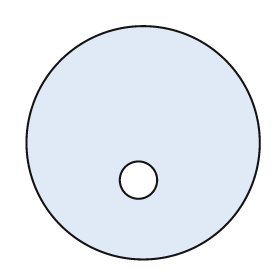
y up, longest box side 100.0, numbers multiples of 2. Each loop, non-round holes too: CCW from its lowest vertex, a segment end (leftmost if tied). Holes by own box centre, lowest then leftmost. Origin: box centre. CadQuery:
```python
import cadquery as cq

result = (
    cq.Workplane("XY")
    .moveTo(0.0, 0.0)
    .circle(50.0)
    .moveTo(-2.0, -16.0)
    .circle(8.0)
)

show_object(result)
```